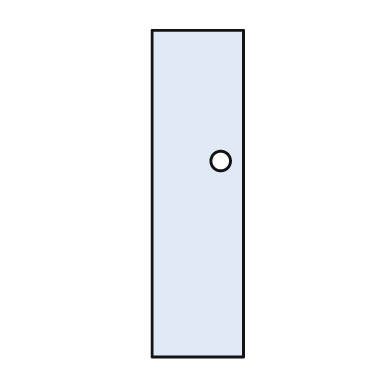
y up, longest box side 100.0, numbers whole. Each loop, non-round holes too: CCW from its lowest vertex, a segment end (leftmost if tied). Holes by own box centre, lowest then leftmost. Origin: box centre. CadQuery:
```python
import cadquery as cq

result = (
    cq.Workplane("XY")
    .moveTo(-14.0, -50.0)
    .lineTo(14.0, -50.0)
    .lineTo(14.0, 50.0)
    .lineTo(-14.0, 50.0)
    .close()
    .moveTo(7.0, 10.0)
    .circle(3.0)
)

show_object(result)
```